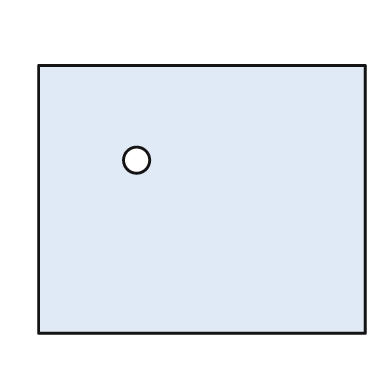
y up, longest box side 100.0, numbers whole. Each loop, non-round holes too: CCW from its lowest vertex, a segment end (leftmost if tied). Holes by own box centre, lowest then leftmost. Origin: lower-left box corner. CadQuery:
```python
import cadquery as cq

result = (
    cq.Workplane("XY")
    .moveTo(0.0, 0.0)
    .lineTo(100.0, 0.0)
    .lineTo(100.0, 82.0)
    .lineTo(0.0, 82.0)
    .close()
    .moveTo(30.0, 53.0)
    .circle(4.0)
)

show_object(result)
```